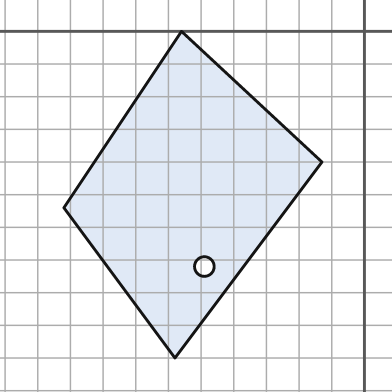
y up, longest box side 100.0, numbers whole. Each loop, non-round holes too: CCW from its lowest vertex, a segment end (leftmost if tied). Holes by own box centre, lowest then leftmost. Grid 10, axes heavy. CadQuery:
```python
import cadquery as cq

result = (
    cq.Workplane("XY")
    .moveTo(-58.0, -100.0)
    .lineTo(-13.0, -40.0)
    .lineTo(-56.0, 0.0)
    .lineTo(-92.0, -54.0)
    .close()
    .moveTo(-49.0, -72.0)
    .circle(3.0)
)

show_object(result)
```